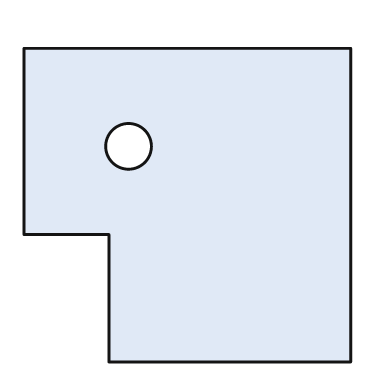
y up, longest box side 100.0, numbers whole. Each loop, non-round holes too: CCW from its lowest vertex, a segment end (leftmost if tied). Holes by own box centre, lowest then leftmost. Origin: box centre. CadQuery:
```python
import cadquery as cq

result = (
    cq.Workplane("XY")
    .moveTo(-24.0, -48.0)
    .lineTo(50.0, -48.0)
    .lineTo(50.0, 48.0)
    .lineTo(-50.0, 48.0)
    .lineTo(-50.0, -9.0)
    .lineTo(-24.0, -9.0)
    .close()
    .moveTo(-18.0, 18.0)
    .circle(7.0)
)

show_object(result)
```